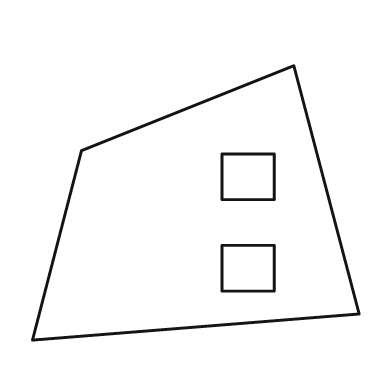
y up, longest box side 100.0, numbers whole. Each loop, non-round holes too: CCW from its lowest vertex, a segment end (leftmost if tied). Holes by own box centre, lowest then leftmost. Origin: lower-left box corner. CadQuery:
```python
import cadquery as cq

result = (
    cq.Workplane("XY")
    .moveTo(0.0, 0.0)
    .lineTo(100.0, 8.0)
    .lineTo(80.0, 84.0)
    .lineTo(15.0, 58.0)
    .close()
    .moveTo(58.0, 15.0)
    .lineTo(74.0, 15.0)
    .lineTo(74.0, 29.0)
    .lineTo(58.0, 29.0)
    .close()
    .moveTo(58.0, 43.0)
    .lineTo(74.0, 43.0)
    .lineTo(74.0, 57.0)
    .lineTo(58.0, 57.0)
    .close()
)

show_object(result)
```